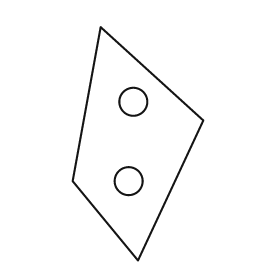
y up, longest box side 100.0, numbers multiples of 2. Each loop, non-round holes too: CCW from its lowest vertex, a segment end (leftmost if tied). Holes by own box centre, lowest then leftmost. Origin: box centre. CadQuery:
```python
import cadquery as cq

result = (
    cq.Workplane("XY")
    .moveTo(0.0, -50.0)
    .lineTo(28.0, 10.0)
    .lineTo(-16.0, 50.0)
    .lineTo(-28.0, -16.0)
    .close()
    .moveTo(-4.0, -16.0)
    .circle(6.0)
    .moveTo(-2.0, 18.0)
    .circle(6.0)
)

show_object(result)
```